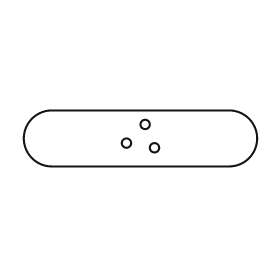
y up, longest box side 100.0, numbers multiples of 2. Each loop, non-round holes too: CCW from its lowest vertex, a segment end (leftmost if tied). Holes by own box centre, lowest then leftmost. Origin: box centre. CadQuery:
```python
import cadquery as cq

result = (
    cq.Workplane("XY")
    .moveTo(-38.0, -12.0)
    .lineTo(38.0, -12.0)
    .threePointArc((50.0, 0.0), (38.0, 12.0))
    .lineTo(-38.0, 12.0)
    .threePointArc((-50.0, 0.0), (-38.0, -12.0))
    .close()
    .moveTo(6.0, -4.0)
    .circle(2.0)
    .moveTo(-6.0, -2.0)
    .circle(2.0)
    .moveTo(2.0, 6.0)
    .circle(2.0)
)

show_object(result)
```